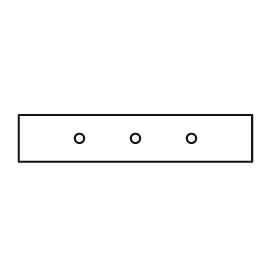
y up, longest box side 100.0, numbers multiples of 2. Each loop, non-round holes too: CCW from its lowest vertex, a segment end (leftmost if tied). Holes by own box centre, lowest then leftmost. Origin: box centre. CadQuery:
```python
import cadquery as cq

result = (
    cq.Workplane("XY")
    .moveTo(-50.0, -10.0)
    .lineTo(50.0, -10.0)
    .lineTo(50.0, 10.0)
    .lineTo(-50.0, 10.0)
    .close()
    .moveTo(-24.0, 0.0)
    .circle(2.0)
    .moveTo(0.0, 0.0)
    .circle(2.0)
    .moveTo(24.0, 0.0)
    .circle(2.0)
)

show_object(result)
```